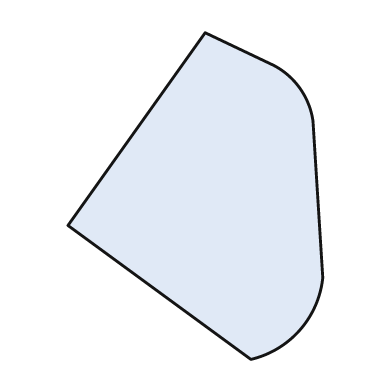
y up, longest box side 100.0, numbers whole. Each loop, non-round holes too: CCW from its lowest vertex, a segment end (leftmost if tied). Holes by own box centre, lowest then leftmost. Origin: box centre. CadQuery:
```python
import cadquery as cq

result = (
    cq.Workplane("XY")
    .moveTo(17.0, -50.0)
    .threePointArc((32.0, -41.0), (39.0, -25.0))
    .lineTo(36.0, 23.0)
    .threePointArc((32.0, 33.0), (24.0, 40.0))
    .lineTo(3.0, 50.0)
    .lineTo(-39.0, -9.0)
    .close()
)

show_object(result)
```